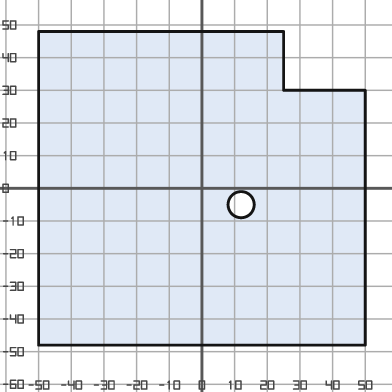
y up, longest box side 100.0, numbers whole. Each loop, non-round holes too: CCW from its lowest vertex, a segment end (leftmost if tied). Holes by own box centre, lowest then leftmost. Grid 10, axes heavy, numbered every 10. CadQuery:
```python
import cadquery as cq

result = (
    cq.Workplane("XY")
    .moveTo(-50.0, -48.0)
    .lineTo(50.0, -48.0)
    .lineTo(50.0, 30.0)
    .lineTo(25.0, 30.0)
    .lineTo(25.0, 48.0)
    .lineTo(-50.0, 48.0)
    .close()
    .moveTo(12.0, -5.0)
    .circle(4.0)
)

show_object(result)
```